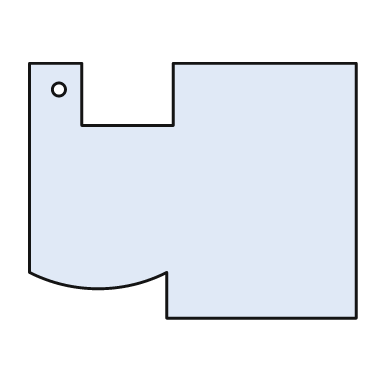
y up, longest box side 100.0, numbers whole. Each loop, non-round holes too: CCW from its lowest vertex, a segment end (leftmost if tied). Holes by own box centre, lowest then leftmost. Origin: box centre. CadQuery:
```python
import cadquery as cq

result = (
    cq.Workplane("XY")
    .moveTo(-8.0, -39.0)
    .lineTo(50.0, -39.0)
    .lineTo(50.0, 39.0)
    .lineTo(-6.0, 39.0)
    .lineTo(-6.0, 20.0)
    .lineTo(-34.0, 20.0)
    .lineTo(-34.0, 39.0)
    .lineTo(-50.0, 39.0)
    .lineTo(-50.0, -25.0)
    .threePointArc((-29.0, -30.0), (-8.0, -25.0))
    .close()
    .moveTo(-41.0, 31.0)
    .circle(2.0)
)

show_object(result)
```